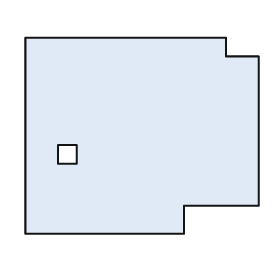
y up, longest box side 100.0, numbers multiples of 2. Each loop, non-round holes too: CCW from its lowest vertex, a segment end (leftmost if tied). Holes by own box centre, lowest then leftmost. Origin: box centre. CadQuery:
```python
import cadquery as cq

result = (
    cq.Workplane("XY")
    .moveTo(-50.0, -42.0)
    .lineTo(18.0, -42.0)
    .lineTo(18.0, -30.0)
    .lineTo(50.0, -30.0)
    .lineTo(50.0, 34.0)
    .lineTo(36.0, 34.0)
    .lineTo(36.0, 42.0)
    .lineTo(-50.0, 42.0)
    .close()
    .moveTo(-36.0, -12.0)
    .lineTo(-28.0, -12.0)
    .lineTo(-28.0, -4.0)
    .lineTo(-36.0, -4.0)
    .close()
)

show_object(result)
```